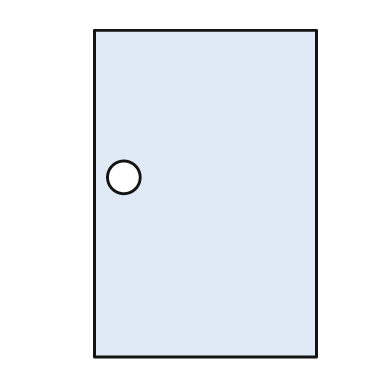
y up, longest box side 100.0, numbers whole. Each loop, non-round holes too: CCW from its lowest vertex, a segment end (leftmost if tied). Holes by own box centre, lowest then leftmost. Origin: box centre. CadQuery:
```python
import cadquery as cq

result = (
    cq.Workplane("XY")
    .moveTo(-34.0, -50.0)
    .lineTo(34.0, -50.0)
    .lineTo(34.0, 50.0)
    .lineTo(-34.0, 50.0)
    .close()
    .moveTo(-25.0, 5.0)
    .circle(5.0)
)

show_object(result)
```